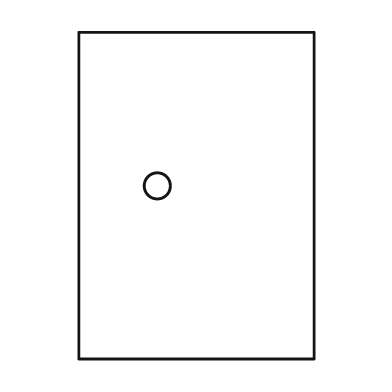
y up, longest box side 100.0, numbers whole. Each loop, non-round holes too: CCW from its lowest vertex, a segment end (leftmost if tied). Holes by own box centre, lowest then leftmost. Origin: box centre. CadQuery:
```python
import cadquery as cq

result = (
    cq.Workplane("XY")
    .moveTo(-36.0, -50.0)
    .lineTo(36.0, -50.0)
    .lineTo(36.0, 50.0)
    .lineTo(-36.0, 50.0)
    .close()
    .moveTo(-12.0, 3.0)
    .circle(4.0)
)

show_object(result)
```